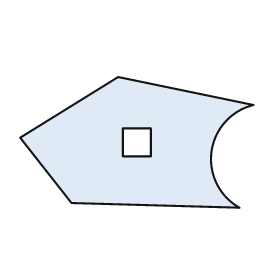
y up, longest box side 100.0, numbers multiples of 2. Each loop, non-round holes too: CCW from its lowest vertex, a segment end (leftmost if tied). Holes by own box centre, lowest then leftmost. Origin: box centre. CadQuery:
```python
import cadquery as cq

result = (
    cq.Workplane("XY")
    .moveTo(44.0, -28.0)
    .threePointArc((32.0, -4.0), (50.0, 16.0))
    .lineTo(-8.0, 28.0)
    .lineTo(-50.0, 2.0)
    .lineTo(-28.0, -26.0)
    .close()
    .moveTo(-6.0, -6.0)
    .lineTo(6.0, -6.0)
    .lineTo(6.0, 6.0)
    .lineTo(-6.0, 6.0)
    .close()
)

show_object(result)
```